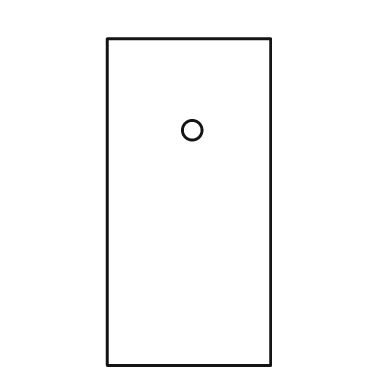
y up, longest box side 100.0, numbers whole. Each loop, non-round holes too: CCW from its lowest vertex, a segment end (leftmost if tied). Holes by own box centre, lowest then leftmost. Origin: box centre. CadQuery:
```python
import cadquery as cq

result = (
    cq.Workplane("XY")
    .moveTo(-25.0, -50.0)
    .lineTo(25.0, -50.0)
    .lineTo(25.0, 50.0)
    .lineTo(-25.0, 50.0)
    .close()
    .moveTo(1.0, 22.0)
    .circle(3.0)
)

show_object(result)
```